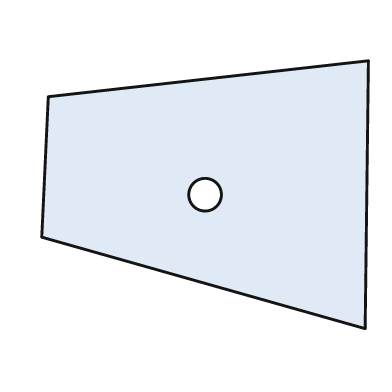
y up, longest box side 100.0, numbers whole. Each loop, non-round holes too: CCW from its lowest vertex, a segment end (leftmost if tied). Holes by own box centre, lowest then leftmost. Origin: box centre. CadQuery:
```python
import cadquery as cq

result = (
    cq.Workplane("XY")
    .moveTo(49.0, -41.0)
    .lineTo(50.0, 41.0)
    .lineTo(-48.0, 30.0)
    .lineTo(-50.0, -13.0)
    .close()
    .moveTo(0.0, 0.0)
    .circle(5.0)
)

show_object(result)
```